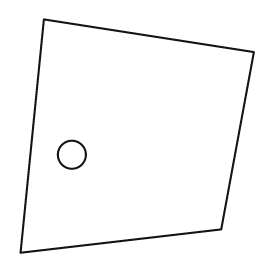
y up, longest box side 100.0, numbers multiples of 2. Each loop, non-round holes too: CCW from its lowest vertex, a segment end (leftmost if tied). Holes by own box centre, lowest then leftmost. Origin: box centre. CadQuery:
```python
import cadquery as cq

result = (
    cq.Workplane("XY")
    .moveTo(-50.0, -50.0)
    .lineTo(36.0, -40.0)
    .lineTo(50.0, 36.0)
    .lineTo(-40.0, 50.0)
    .close()
    .moveTo(-28.0, -8.0)
    .circle(6.0)
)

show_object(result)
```